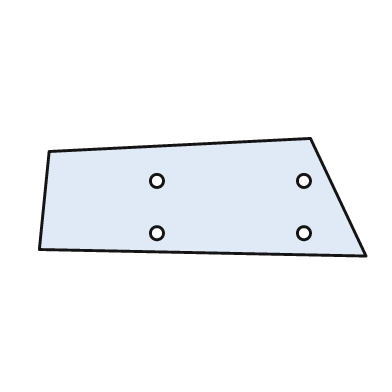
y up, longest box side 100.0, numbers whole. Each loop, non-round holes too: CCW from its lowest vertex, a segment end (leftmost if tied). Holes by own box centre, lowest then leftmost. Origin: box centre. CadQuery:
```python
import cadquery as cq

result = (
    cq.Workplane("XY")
    .moveTo(50.0, -18.0)
    .lineTo(33.0, 18.0)
    .lineTo(-47.0, 14.0)
    .lineTo(-50.0, -16.0)
    .close()
    .moveTo(-14.0, -11.0)
    .circle(2.0)
    .moveTo(31.0, -11.0)
    .circle(2.0)
    .moveTo(-14.0, 5.0)
    .circle(2.0)
    .moveTo(31.0, 5.0)
    .circle(2.0)
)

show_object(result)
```